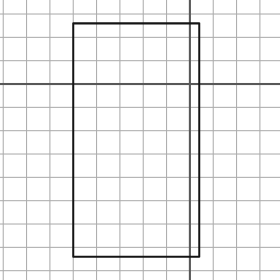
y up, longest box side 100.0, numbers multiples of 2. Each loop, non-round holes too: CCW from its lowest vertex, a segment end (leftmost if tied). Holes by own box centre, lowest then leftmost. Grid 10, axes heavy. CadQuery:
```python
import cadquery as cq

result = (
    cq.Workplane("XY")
    .moveTo(-50.0, -74.0)
    .lineTo(4.0, -74.0)
    .lineTo(4.0, 26.0)
    .lineTo(-50.0, 26.0)
    .close()
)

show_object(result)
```